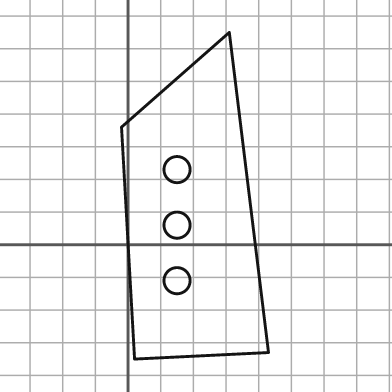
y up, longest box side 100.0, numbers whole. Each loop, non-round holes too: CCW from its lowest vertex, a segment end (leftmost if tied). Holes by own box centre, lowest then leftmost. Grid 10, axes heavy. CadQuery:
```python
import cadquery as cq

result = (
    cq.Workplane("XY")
    .moveTo(2.0, -35.0)
    .lineTo(43.0, -33.0)
    .lineTo(31.0, 65.0)
    .lineTo(-2.0, 36.0)
    .close()
    .moveTo(15.0, -11.0)
    .circle(4.0)
    .moveTo(15.0, 6.0)
    .circle(4.0)
    .moveTo(15.0, 23.0)
    .circle(4.0)
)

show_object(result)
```